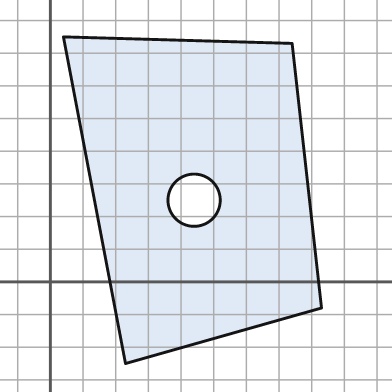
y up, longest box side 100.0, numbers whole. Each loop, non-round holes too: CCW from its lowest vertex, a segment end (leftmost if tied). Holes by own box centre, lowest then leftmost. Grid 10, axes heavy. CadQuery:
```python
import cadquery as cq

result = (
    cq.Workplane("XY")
    .moveTo(23.0, -25.0)
    .lineTo(83.0, -8.0)
    .lineTo(74.0, 73.0)
    .lineTo(4.0, 75.0)
    .close()
    .moveTo(44.0, 25.0)
    .circle(8.0)
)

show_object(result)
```